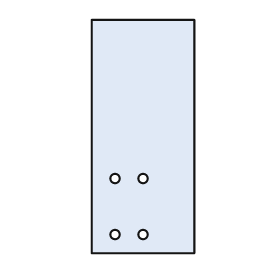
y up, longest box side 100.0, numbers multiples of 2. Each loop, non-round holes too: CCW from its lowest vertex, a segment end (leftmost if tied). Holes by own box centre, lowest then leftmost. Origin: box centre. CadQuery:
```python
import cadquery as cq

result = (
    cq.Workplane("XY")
    .moveTo(-22.0, -50.0)
    .lineTo(22.0, -50.0)
    .lineTo(22.0, 50.0)
    .lineTo(-22.0, 50.0)
    .close()
    .moveTo(-12.0, -42.0)
    .circle(2.0)
    .moveTo(0.0, -42.0)
    .circle(2.0)
    .moveTo(-12.0, -18.0)
    .circle(2.0)
    .moveTo(0.0, -18.0)
    .circle(2.0)
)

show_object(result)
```